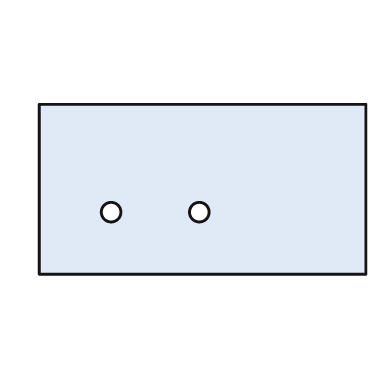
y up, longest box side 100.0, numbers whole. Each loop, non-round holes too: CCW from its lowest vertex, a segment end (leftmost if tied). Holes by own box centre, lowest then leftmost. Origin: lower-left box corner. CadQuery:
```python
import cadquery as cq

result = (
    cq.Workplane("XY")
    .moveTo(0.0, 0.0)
    .lineTo(100.0, 0.0)
    .lineTo(100.0, 52.0)
    .lineTo(0.0, 52.0)
    .close()
    .moveTo(22.0, 19.0)
    .circle(3.0)
    .moveTo(49.0, 19.0)
    .circle(3.0)
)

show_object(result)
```